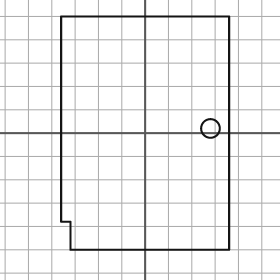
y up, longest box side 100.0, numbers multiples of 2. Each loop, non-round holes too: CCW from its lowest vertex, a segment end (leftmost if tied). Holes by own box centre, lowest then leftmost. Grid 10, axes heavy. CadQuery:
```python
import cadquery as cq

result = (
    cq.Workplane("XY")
    .moveTo(-32.0, -50.0)
    .lineTo(36.0, -50.0)
    .lineTo(36.0, 50.0)
    .lineTo(-36.0, 50.0)
    .lineTo(-36.0, -38.0)
    .lineTo(-32.0, -38.0)
    .close()
    .moveTo(28.0, 2.0)
    .circle(4.0)
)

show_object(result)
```